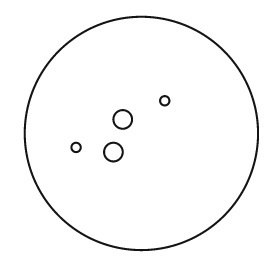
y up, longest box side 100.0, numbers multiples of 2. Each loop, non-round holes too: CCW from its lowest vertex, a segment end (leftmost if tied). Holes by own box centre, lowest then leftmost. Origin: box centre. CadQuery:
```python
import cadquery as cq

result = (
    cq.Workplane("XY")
    .moveTo(0.0, 0.0)
    .circle(50.0)
    .moveTo(-12.0, -8.0)
    .circle(4.0)
    .moveTo(-28.0, -6.0)
    .circle(2.0)
    .moveTo(-8.0, 6.0)
    .circle(4.0)
    .moveTo(10.0, 14.0)
    .circle(2.0)
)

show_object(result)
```